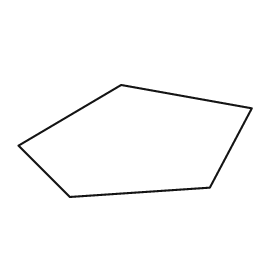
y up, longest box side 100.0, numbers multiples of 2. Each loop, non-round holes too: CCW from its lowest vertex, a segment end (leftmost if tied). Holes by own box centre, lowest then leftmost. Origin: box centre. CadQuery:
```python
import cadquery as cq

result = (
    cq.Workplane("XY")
    .moveTo(-28.0, -24.0)
    .lineTo(32.0, -20.0)
    .lineTo(50.0, 14.0)
    .lineTo(-6.0, 24.0)
    .lineTo(-50.0, -2.0)
    .close()
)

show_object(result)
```